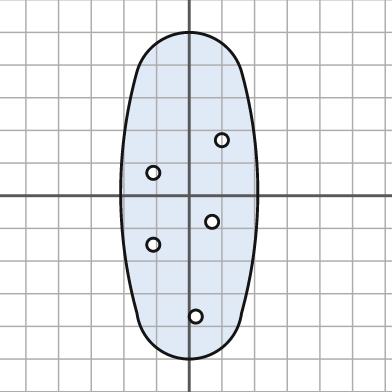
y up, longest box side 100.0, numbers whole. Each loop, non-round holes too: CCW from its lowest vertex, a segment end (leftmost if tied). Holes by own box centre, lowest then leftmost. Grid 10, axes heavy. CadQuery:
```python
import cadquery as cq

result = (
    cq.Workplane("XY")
    .moveTo(-16.0, -36.0)
    .threePointArc((0.0, -50.0), (16.0, -36.0))
    .threePointArc((21.0, 1.0), (16.0, 38.0))
    .threePointArc((0.0, 50.0), (-16.0, 38.0))
    .threePointArc((-21.0, 1.0), (-16.0, -36.0))
    .close()
    .moveTo(2.0, -37.0)
    .circle(2.0)
    .moveTo(-11.0, -15.0)
    .circle(2.0)
    .moveTo(7.0, -8.0)
    .circle(2.0)
    .moveTo(-11.0, 7.0)
    .circle(2.0)
    .moveTo(10.0, 17.0)
    .circle(2.0)
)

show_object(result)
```